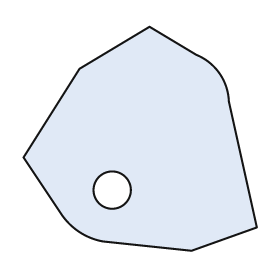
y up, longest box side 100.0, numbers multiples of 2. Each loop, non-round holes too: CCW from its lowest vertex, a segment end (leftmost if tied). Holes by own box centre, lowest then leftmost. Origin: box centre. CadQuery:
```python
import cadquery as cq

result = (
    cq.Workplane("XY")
    .moveTo(22.0, -48.0)
    .lineTo(50.0, -38.0)
    .lineTo(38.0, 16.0)
    .threePointArc((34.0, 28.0), (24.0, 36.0))
    .lineTo(4.0, 48.0)
    .lineTo(-26.0, 30.0)
    .lineTo(-50.0, -8.0)
    .lineTo(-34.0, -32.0)
    .threePointArc((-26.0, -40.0), (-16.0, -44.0))
    .close()
    .moveTo(-12.0, -22.0)
    .circle(8.0)
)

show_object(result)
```